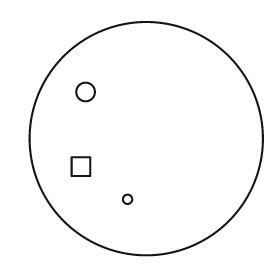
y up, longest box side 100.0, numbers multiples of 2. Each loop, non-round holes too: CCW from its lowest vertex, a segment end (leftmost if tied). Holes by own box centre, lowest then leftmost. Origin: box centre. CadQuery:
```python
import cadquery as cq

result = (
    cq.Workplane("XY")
    .moveTo(0.0, 0.0)
    .circle(50.0)
    .moveTo(-8.0, -26.0)
    .circle(2.0)
    .moveTo(-32.0, -16.0)
    .lineTo(-24.0, -16.0)
    .lineTo(-24.0, -8.0)
    .lineTo(-32.0, -8.0)
    .close()
    .moveTo(-26.0, 20.0)
    .circle(4.0)
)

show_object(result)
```